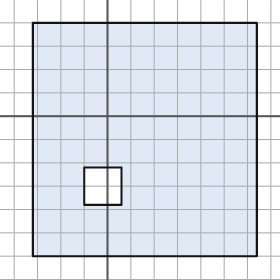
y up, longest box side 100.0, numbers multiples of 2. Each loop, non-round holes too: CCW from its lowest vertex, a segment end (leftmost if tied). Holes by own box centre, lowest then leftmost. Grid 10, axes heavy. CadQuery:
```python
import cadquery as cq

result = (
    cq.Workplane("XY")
    .moveTo(-32.0, -60.0)
    .lineTo(64.0, -60.0)
    .lineTo(64.0, 40.0)
    .lineTo(-32.0, 40.0)
    .close()
    .moveTo(-10.0, -38.0)
    .lineTo(6.0, -38.0)
    .lineTo(6.0, -22.0)
    .lineTo(-10.0, -22.0)
    .close()
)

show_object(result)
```